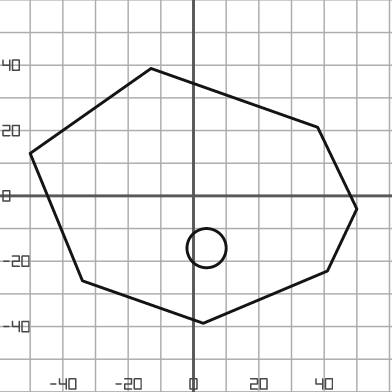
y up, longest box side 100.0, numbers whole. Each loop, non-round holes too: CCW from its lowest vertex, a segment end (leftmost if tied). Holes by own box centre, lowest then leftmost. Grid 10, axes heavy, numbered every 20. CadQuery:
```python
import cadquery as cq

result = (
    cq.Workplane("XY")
    .moveTo(3.0, -39.0)
    .lineTo(41.0, -23.0)
    .lineTo(50.0, -4.0)
    .lineTo(38.0, 21.0)
    .lineTo(-13.0, 39.0)
    .lineTo(-50.0, 13.0)
    .lineTo(-34.0, -26.0)
    .close()
    .moveTo(4.0, -16.0)
    .circle(6.0)
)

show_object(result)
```